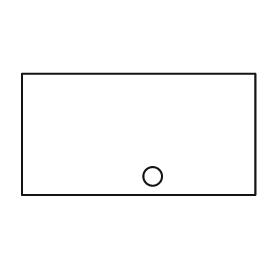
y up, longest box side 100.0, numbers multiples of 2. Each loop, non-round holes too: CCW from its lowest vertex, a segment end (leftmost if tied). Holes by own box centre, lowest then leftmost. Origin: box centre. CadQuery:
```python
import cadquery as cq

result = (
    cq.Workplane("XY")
    .moveTo(-50.0, -26.0)
    .lineTo(50.0, -26.0)
    .lineTo(50.0, 26.0)
    .lineTo(-50.0, 26.0)
    .close()
    .moveTo(6.0, -18.0)
    .circle(4.0)
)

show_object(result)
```